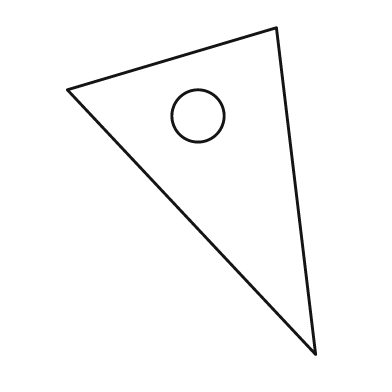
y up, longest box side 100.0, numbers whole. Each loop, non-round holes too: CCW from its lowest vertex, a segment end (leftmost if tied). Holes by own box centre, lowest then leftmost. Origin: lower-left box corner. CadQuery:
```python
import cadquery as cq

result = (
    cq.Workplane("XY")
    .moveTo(76.0, 0.0)
    .lineTo(64.0, 100.0)
    .lineTo(0.0, 81.0)
    .close()
    .moveTo(40.0, 73.0)
    .circle(8.0)
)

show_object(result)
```